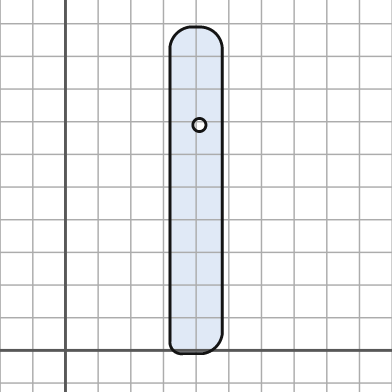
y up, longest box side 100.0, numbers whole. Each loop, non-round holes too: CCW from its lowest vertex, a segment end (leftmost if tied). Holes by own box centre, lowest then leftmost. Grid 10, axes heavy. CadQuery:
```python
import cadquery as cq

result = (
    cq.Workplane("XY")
    .moveTo(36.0, -1.0)
    .lineTo(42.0, -1.0)
    .threePointArc((46.0, 1.0), (48.0, 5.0))
    .lineTo(48.0, 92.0)
    .threePointArc((46.0, 97.0), (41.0, 99.0))
    .lineTo(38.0, 99.0)
    .threePointArc((34.0, 97.0), (32.0, 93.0))
    .lineTo(32.0, 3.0)
    .threePointArc((33.0, 0.0), (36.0, -1.0))
    .close()
    .moveTo(41.0, 69.0)
    .circle(2.0)
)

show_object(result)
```